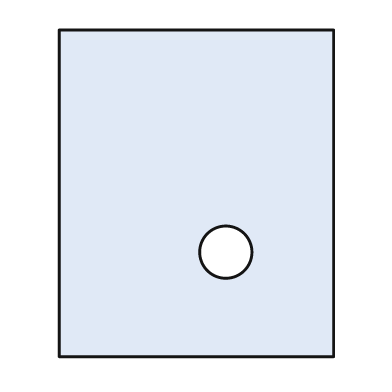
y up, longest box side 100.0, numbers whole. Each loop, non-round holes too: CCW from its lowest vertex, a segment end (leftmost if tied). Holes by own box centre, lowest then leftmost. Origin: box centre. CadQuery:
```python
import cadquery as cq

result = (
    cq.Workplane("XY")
    .moveTo(-42.0, -50.0)
    .lineTo(42.0, -50.0)
    .lineTo(42.0, 50.0)
    .lineTo(-42.0, 50.0)
    .close()
    .moveTo(9.0, -18.0)
    .circle(8.0)
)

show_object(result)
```